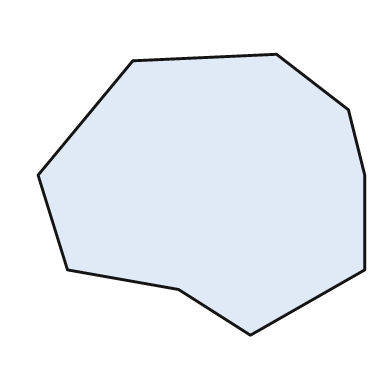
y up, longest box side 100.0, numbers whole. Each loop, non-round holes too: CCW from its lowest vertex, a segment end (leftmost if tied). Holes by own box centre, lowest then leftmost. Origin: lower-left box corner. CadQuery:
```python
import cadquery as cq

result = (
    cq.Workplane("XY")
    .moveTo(65.0, 0.0)
    .lineTo(100.0, 20.0)
    .lineTo(100.0, 49.0)
    .lineTo(95.0, 69.0)
    .lineTo(73.0, 86.0)
    .lineTo(29.0, 84.0)
    .lineTo(0.0, 49.0)
    .lineTo(9.0, 20.0)
    .lineTo(43.0, 14.0)
    .close()
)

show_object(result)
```